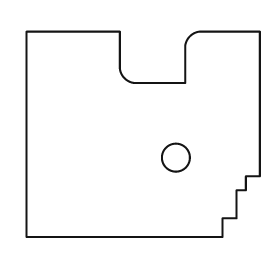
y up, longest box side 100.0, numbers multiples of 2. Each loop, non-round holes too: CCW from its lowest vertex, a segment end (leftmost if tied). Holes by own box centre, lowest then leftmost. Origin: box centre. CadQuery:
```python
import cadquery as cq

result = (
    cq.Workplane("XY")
    .moveTo(-50.0, -44.0)
    .lineTo(34.0, -44.0)
    .lineTo(34.0, -36.0)
    .lineTo(40.0, -36.0)
    .lineTo(40.0, -24.0)
    .lineTo(44.0, -24.0)
    .lineTo(44.0, -18.0)
    .lineTo(50.0, -18.0)
    .lineTo(50.0, 44.0)
    .lineTo(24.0, 44.0)
    .threePointArc((20.0, 42.0), (18.0, 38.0))
    .lineTo(18.0, 22.0)
    .lineTo(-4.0, 22.0)
    .threePointArc((-8.0, 24.0), (-10.0, 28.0))
    .lineTo(-10.0, 44.0)
    .lineTo(-50.0, 44.0)
    .close()
    .moveTo(14.0, -10.0)
    .circle(6.0)
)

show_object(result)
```